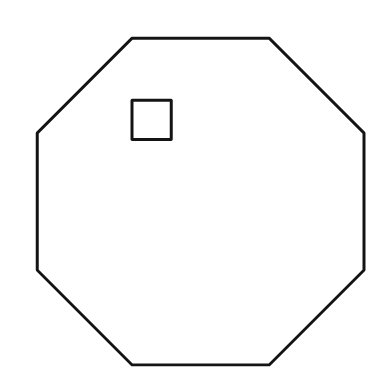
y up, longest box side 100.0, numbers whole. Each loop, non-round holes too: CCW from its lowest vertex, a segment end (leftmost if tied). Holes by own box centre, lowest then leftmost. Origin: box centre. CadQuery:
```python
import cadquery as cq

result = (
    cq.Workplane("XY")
    .moveTo(-21.0, -50.0)
    .lineTo(21.0, -50.0)
    .lineTo(50.0, -21.0)
    .lineTo(50.0, 21.0)
    .lineTo(21.0, 50.0)
    .lineTo(-21.0, 50.0)
    .lineTo(-50.0, 21.0)
    .lineTo(-50.0, -21.0)
    .close()
    .moveTo(-21.0, 19.0)
    .lineTo(-9.0, 19.0)
    .lineTo(-9.0, 31.0)
    .lineTo(-21.0, 31.0)
    .close()
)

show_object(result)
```